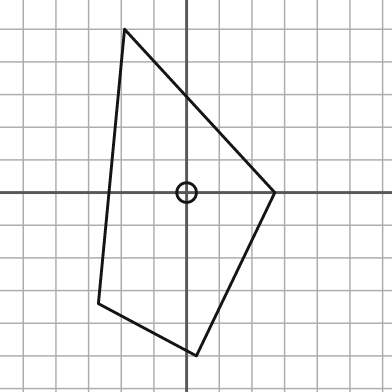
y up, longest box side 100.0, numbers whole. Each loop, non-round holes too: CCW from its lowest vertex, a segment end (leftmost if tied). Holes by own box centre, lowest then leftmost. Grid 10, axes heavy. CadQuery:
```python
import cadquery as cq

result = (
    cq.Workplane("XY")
    .moveTo(3.0, -50.0)
    .lineTo(27.0, 0.0)
    .lineTo(-19.0, 50.0)
    .lineTo(-27.0, -34.0)
    .close()
    .moveTo(0.0, 0.0)
    .circle(3.0)
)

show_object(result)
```